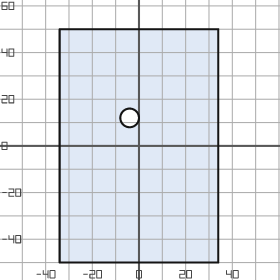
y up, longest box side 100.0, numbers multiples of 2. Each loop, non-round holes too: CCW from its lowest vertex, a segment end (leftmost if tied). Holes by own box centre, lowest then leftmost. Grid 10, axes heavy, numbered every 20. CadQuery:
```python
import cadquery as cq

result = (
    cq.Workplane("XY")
    .moveTo(-34.0, -50.0)
    .lineTo(34.0, -50.0)
    .lineTo(34.0, 50.0)
    .lineTo(-34.0, 50.0)
    .close()
    .moveTo(-4.0, 12.0)
    .circle(4.0)
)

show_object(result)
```